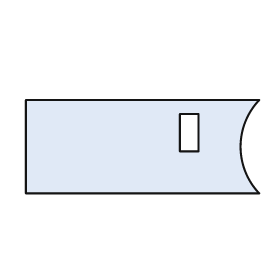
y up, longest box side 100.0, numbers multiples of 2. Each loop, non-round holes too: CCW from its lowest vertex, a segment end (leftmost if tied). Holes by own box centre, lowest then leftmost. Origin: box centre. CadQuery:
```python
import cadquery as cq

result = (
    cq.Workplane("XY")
    .moveTo(-50.0, -20.0)
    .lineTo(50.0, -20.0)
    .threePointArc((42.0, 0.0), (50.0, 20.0))
    .lineTo(-50.0, 20.0)
    .close()
    .moveTo(16.0, -2.0)
    .lineTo(24.0, -2.0)
    .lineTo(24.0, 14.0)
    .lineTo(16.0, 14.0)
    .close()
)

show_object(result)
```